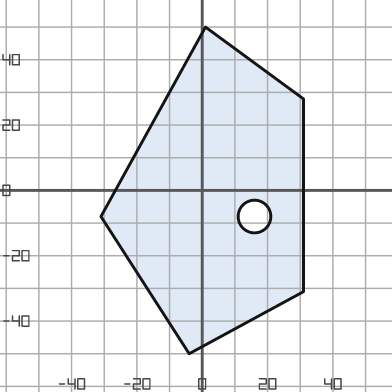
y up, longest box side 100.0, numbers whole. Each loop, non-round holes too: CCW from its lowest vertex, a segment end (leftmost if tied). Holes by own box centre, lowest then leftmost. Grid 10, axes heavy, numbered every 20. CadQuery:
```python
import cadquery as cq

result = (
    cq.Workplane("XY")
    .moveTo(-4.0, -50.0)
    .lineTo(31.0, -31.0)
    .lineTo(31.0, 28.0)
    .lineTo(1.0, 50.0)
    .lineTo(-31.0, -8.0)
    .close()
    .moveTo(16.0, -8.0)
    .circle(5.0)
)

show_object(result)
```